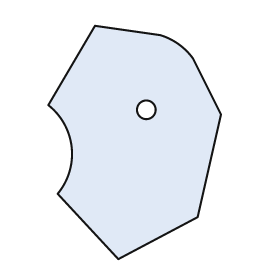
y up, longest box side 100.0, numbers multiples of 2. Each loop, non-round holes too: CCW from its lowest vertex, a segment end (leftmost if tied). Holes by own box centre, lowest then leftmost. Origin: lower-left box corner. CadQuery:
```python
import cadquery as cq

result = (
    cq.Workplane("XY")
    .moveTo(30.0, 0.0)
    .lineTo(64.0, 18.0)
    .lineTo(74.0, 62.0)
    .lineTo(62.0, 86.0)
    .threePointArc((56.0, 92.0), (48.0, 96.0))
    .lineTo(20.0, 100.0)
    .lineTo(0.0, 66.0)
    .threePointArc((10.0, 48.0), (4.0, 28.0))
    .close()
    .moveTo(42.0, 64.0)
    .circle(4.0)
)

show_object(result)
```